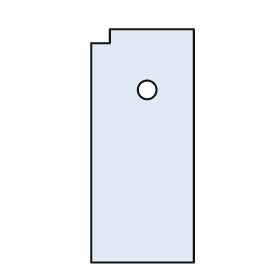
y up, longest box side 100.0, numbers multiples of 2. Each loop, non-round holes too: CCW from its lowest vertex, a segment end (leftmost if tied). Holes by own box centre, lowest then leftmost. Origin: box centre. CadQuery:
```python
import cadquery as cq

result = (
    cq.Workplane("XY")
    .moveTo(-22.0, -50.0)
    .lineTo(22.0, -50.0)
    .lineTo(22.0, 50.0)
    .lineTo(-14.0, 50.0)
    .lineTo(-14.0, 44.0)
    .lineTo(-22.0, 44.0)
    .close()
    .moveTo(2.0, 24.0)
    .circle(4.0)
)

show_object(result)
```